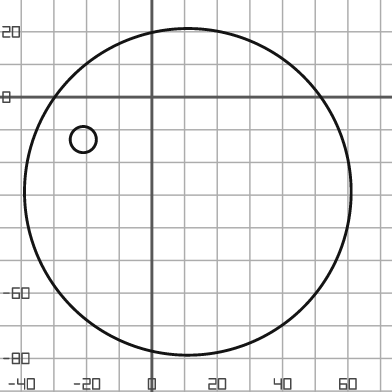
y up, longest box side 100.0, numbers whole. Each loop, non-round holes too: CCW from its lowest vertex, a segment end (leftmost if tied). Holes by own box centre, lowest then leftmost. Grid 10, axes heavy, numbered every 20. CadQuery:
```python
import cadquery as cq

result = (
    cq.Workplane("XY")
    .moveTo(11.0, -29.0)
    .circle(50.0)
    .moveTo(-21.0, -13.0)
    .circle(4.0)
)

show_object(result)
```